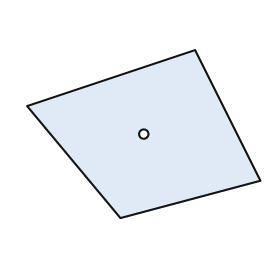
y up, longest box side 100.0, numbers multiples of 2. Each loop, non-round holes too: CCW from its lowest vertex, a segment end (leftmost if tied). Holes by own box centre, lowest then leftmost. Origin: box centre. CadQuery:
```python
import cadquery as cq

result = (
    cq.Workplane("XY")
    .moveTo(-10.0, -36.0)
    .lineTo(50.0, -20.0)
    .lineTo(22.0, 36.0)
    .lineTo(-50.0, 12.0)
    .close()
    .moveTo(0.0, 0.0)
    .circle(2.0)
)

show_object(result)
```